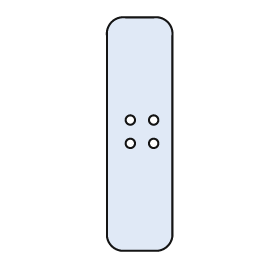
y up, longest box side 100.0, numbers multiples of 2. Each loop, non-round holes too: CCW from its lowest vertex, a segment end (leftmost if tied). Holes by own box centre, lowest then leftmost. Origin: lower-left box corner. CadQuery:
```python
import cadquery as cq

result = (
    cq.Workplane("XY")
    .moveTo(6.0, 0.0)
    .lineTo(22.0, 0.0)
    .threePointArc((26.0, 2.0), (28.0, 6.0))
    .lineTo(28.0, 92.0)
    .threePointArc((26.0, 98.0), (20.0, 100.0))
    .lineTo(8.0, 100.0)
    .threePointArc((2.0, 98.0), (0.0, 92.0))
    .lineTo(0.0, 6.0)
    .threePointArc((2.0, 2.0), (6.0, 0.0))
    .close()
    .moveTo(10.0, 46.0)
    .circle(2.0)
    .moveTo(20.0, 46.0)
    .circle(2.0)
    .moveTo(10.0, 56.0)
    .circle(2.0)
    .moveTo(20.0, 56.0)
    .circle(2.0)
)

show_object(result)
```